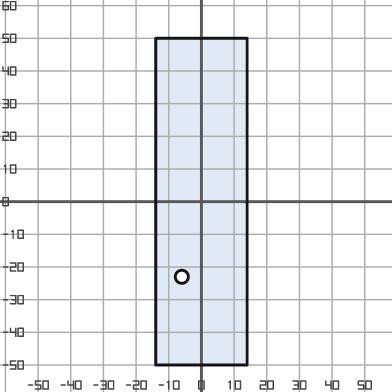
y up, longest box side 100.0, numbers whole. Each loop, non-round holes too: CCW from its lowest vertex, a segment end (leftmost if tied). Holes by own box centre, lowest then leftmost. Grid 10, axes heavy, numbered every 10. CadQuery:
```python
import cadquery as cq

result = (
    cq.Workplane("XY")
    .moveTo(-14.0, -50.0)
    .lineTo(14.0, -50.0)
    .lineTo(14.0, 50.0)
    .lineTo(-14.0, 50.0)
    .close()
    .moveTo(-6.0, -23.0)
    .circle(2.0)
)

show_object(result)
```